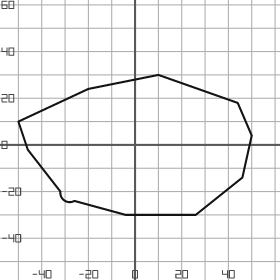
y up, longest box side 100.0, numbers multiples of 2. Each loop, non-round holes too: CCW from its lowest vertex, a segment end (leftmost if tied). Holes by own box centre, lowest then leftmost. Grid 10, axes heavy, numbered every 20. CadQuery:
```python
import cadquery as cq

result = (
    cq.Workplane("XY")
    .moveTo(-4.0, -30.0)
    .lineTo(26.0, -30.0)
    .lineTo(46.0, -14.0)
    .lineTo(50.0, 4.0)
    .lineTo(44.0, 18.0)
    .lineTo(10.0, 30.0)
    .lineTo(-20.0, 24.0)
    .lineTo(-50.0, 10.0)
    .lineTo(-46.0, -2.0)
    .lineTo(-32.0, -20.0)
    .threePointArc((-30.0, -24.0), (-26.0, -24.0))
    .close()
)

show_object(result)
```